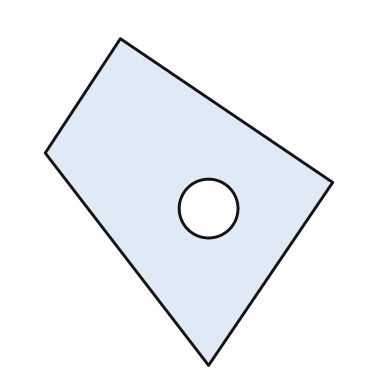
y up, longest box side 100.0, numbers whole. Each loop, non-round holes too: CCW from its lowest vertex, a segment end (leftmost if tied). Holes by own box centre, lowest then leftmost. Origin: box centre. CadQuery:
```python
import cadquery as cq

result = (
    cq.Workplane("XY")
    .moveTo(6.0, -50.0)
    .lineTo(44.0, 6.0)
    .lineTo(-21.0, 50.0)
    .lineTo(-44.0, 15.0)
    .close()
    .moveTo(6.0, -2.0)
    .circle(9.0)
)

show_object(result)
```